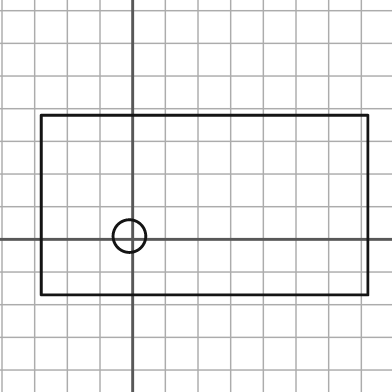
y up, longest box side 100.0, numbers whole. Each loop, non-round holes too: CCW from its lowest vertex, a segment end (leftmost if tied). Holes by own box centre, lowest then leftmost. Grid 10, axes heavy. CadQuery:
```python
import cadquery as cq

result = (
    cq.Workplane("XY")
    .moveTo(-28.0, -17.0)
    .lineTo(72.0, -17.0)
    .lineTo(72.0, 38.0)
    .lineTo(-28.0, 38.0)
    .close()
    .moveTo(-1.0, 1.0)
    .circle(5.0)
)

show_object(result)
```